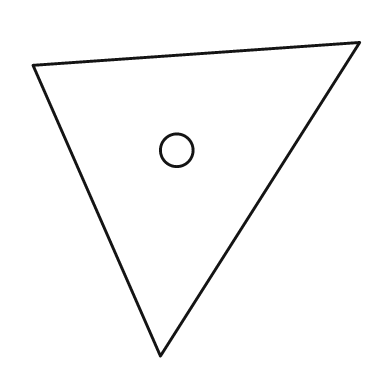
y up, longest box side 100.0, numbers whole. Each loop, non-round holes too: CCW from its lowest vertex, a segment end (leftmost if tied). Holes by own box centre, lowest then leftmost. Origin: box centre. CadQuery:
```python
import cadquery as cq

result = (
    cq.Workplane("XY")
    .moveTo(-11.0, -48.0)
    .lineTo(50.0, 48.0)
    .lineTo(-50.0, 41.0)
    .close()
    .moveTo(-6.0, 15.0)
    .circle(5.0)
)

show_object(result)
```